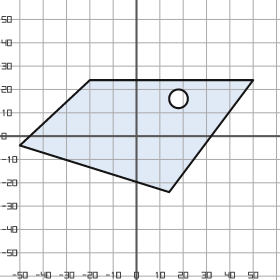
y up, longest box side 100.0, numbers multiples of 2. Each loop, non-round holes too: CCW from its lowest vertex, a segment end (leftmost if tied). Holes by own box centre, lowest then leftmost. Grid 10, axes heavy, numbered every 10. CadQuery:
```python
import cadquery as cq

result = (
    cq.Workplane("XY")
    .moveTo(14.0, -24.0)
    .lineTo(50.0, 24.0)
    .lineTo(-20.0, 24.0)
    .lineTo(-50.0, -4.0)
    .close()
    .moveTo(18.0, 16.0)
    .circle(4.0)
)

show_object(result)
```